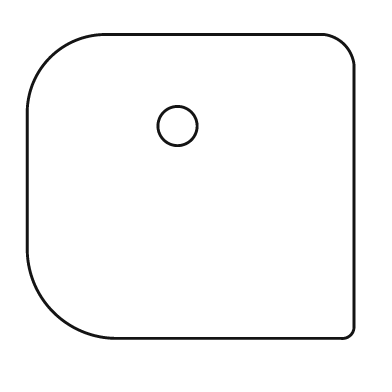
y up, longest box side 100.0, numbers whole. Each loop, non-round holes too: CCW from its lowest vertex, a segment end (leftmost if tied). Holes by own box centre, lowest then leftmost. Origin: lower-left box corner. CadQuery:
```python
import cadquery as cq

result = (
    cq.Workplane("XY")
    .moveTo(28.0, 0.0)
    .lineTo(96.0, 0.0)
    .threePointArc((99.0, 1.0), (100.0, 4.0))
    .lineTo(100.0, 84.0)
    .threePointArc((97.0, 90.0), (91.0, 93.0))
    .lineTo(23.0, 93.0)
    .threePointArc((7.0, 86.0), (0.0, 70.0))
    .lineTo(0.0, 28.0)
    .threePointArc((8.0, 8.0), (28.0, 0.0))
    .close()
    .moveTo(46.0, 65.0)
    .circle(6.0)
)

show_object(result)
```